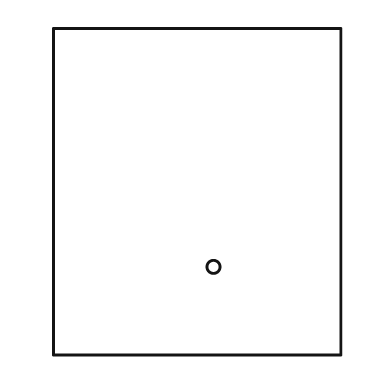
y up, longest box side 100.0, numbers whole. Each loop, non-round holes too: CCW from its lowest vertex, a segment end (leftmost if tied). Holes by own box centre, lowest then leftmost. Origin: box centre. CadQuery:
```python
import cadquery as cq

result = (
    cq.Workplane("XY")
    .moveTo(-44.0, -50.0)
    .lineTo(44.0, -50.0)
    .lineTo(44.0, 50.0)
    .lineTo(-44.0, 50.0)
    .close()
    .moveTo(5.0, -23.0)
    .circle(2.0)
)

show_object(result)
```